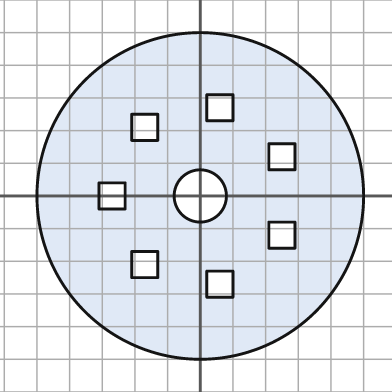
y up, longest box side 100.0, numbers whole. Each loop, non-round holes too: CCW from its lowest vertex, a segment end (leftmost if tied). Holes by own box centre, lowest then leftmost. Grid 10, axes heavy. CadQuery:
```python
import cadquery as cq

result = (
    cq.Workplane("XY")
    .moveTo(0.0, 0.0)
    .circle(50.0)
    .moveTo(2.0, -31.0)
    .lineTo(10.0, -31.0)
    .lineTo(10.0, -23.0)
    .lineTo(2.0, -23.0)
    .close()
    .moveTo(-21.0, -25.0)
    .lineTo(-13.0, -25.0)
    .lineTo(-13.0, -17.0)
    .lineTo(-21.0, -17.0)
    .close()
    .moveTo(21.0, -16.0)
    .lineTo(29.0, -16.0)
    .lineTo(29.0, -8.0)
    .lineTo(21.0, -8.0)
    .close()
    .moveTo(-31.0, -4.0)
    .lineTo(-23.0, -4.0)
    .lineTo(-23.0, 4.0)
    .lineTo(-31.0, 4.0)
    .close()
    .moveTo(0.0, 0.0)
    .circle(8.0)
    .moveTo(21.0, 8.0)
    .lineTo(29.0, 8.0)
    .lineTo(29.0, 16.0)
    .lineTo(21.0, 16.0)
    .close()
    .moveTo(-21.0, 17.0)
    .lineTo(-13.0, 17.0)
    .lineTo(-13.0, 25.0)
    .lineTo(-21.0, 25.0)
    .close()
    .moveTo(2.0, 23.0)
    .lineTo(10.0, 23.0)
    .lineTo(10.0, 31.0)
    .lineTo(2.0, 31.0)
    .close()
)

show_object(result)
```